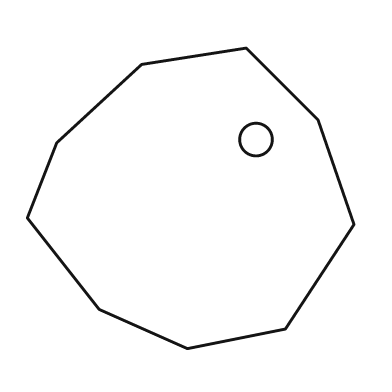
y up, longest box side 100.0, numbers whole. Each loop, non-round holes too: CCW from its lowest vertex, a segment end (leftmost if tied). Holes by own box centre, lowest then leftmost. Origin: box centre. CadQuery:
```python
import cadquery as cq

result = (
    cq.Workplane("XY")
    .moveTo(-1.0, -46.0)
    .lineTo(29.0, -40.0)
    .lineTo(50.0, -8.0)
    .lineTo(39.0, 24.0)
    .lineTo(17.0, 46.0)
    .lineTo(-15.0, 41.0)
    .lineTo(-41.0, 17.0)
    .lineTo(-50.0, -6.0)
    .lineTo(-28.0, -34.0)
    .close()
    .moveTo(20.0, 18.0)
    .circle(5.0)
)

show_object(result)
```